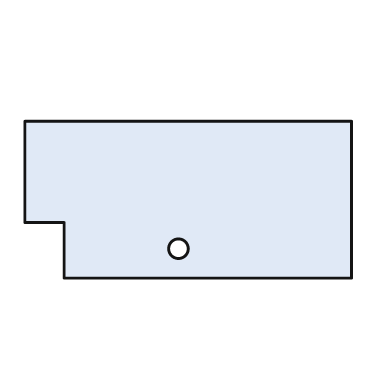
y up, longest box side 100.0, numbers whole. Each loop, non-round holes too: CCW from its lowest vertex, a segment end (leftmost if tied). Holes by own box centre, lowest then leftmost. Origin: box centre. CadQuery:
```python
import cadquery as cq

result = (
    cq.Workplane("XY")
    .moveTo(-38.0, -24.0)
    .lineTo(50.0, -24.0)
    .lineTo(50.0, 24.0)
    .lineTo(-50.0, 24.0)
    .lineTo(-50.0, -7.0)
    .lineTo(-38.0, -7.0)
    .close()
    .moveTo(-3.0, -15.0)
    .circle(3.0)
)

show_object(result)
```